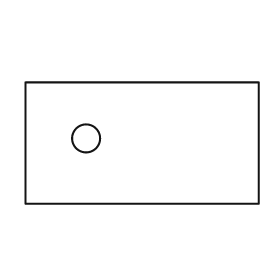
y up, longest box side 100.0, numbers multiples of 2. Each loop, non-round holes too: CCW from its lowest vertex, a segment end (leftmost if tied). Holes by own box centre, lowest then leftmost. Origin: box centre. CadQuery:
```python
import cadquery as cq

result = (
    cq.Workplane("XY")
    .moveTo(-50.0, -26.0)
    .lineTo(50.0, -26.0)
    .lineTo(50.0, 26.0)
    .lineTo(-50.0, 26.0)
    .close()
    .moveTo(-24.0, 2.0)
    .circle(6.0)
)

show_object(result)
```